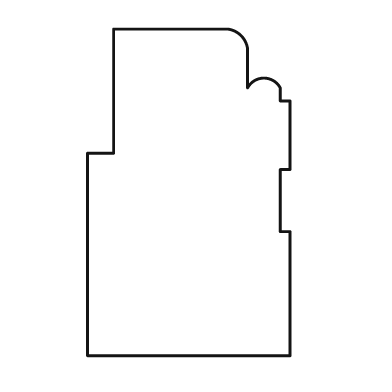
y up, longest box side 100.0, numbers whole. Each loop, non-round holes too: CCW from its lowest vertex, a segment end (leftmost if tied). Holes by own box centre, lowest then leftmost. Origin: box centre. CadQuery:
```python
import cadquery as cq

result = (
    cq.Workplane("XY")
    .moveTo(-31.0, -50.0)
    .lineTo(31.0, -50.0)
    .lineTo(31.0, -12.0)
    .lineTo(28.0, -12.0)
    .lineTo(28.0, 7.0)
    .lineTo(31.0, 7.0)
    .lineTo(31.0, 28.0)
    .lineTo(28.0, 28.0)
    .lineTo(28.0, 32.0)
    .threePointArc((23.0, 35.0), (18.0, 32.0))
    .lineTo(18.0, 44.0)
    .threePointArc((16.0, 48.0), (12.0, 50.0))
    .lineTo(-23.0, 50.0)
    .lineTo(-23.0, 12.0)
    .lineTo(-31.0, 12.0)
    .close()
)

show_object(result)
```